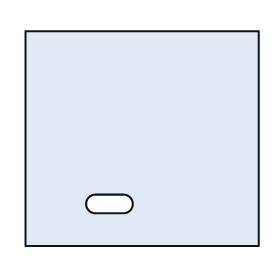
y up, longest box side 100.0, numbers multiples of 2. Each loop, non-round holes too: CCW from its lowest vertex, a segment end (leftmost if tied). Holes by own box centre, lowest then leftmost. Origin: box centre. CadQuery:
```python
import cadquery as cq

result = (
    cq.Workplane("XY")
    .moveTo(-50.0, -46.0)
    .lineTo(50.0, -46.0)
    .lineTo(50.0, 46.0)
    .lineTo(-50.0, 46.0)
    .close()
    .moveTo(-20.0, -32.0)
    .lineTo(-8.0, -32.0)
    .threePointArc((-4.0, -28.0), (-8.0, -24.0))
    .lineTo(-20.0, -24.0)
    .threePointArc((-24.0, -28.0), (-20.0, -32.0))
    .close()
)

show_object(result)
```